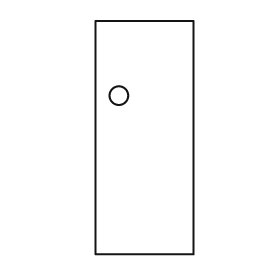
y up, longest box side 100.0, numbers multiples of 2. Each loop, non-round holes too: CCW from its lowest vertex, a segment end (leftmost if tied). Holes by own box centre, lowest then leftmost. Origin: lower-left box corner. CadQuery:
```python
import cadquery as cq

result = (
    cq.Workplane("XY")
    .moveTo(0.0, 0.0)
    .lineTo(42.0, 0.0)
    .lineTo(42.0, 100.0)
    .lineTo(0.0, 100.0)
    .close()
    .moveTo(10.0, 68.0)
    .circle(4.0)
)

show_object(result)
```